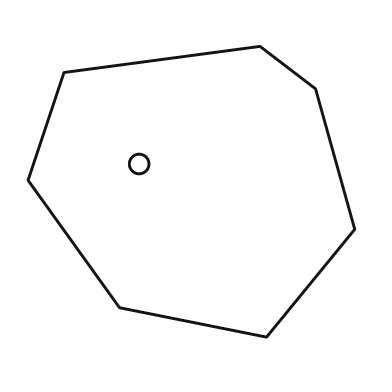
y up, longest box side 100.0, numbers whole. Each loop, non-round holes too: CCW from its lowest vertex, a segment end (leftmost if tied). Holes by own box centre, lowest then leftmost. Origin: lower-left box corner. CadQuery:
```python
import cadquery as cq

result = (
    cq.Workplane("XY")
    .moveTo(73.0, 0.0)
    .lineTo(100.0, 33.0)
    .lineTo(88.0, 76.0)
    .lineTo(71.0, 89.0)
    .lineTo(11.0, 81.0)
    .lineTo(0.0, 48.0)
    .lineTo(28.0, 9.0)
    .close()
    .moveTo(34.0, 53.0)
    .circle(3.0)
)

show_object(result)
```